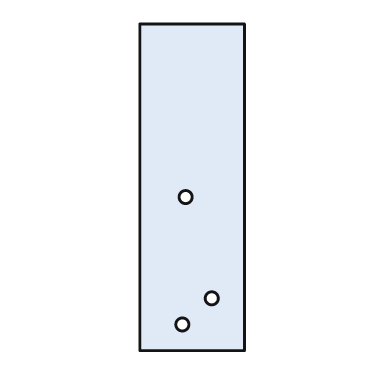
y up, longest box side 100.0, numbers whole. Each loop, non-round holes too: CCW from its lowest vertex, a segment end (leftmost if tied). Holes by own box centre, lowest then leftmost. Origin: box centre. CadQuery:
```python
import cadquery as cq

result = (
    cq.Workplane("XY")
    .moveTo(-16.0, -50.0)
    .lineTo(16.0, -50.0)
    .lineTo(16.0, 50.0)
    .lineTo(-16.0, 50.0)
    .close()
    .moveTo(-3.0, -42.0)
    .circle(2.0)
    .moveTo(6.0, -34.0)
    .circle(2.0)
    .moveTo(-2.0, -3.0)
    .circle(2.0)
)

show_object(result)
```